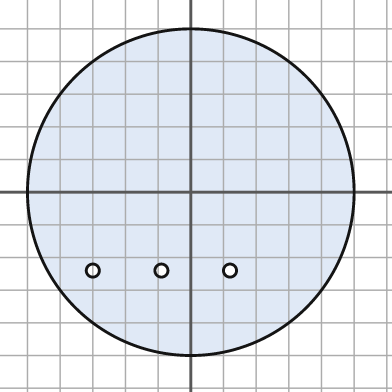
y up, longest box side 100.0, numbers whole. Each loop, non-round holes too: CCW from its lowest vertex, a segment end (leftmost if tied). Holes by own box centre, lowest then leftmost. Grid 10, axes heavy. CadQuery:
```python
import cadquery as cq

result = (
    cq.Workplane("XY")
    .moveTo(0.0, 0.0)
    .circle(50.0)
    .moveTo(-30.0, -24.0)
    .circle(2.0)
    .moveTo(-9.0, -24.0)
    .circle(2.0)
    .moveTo(12.0, -24.0)
    .circle(2.0)
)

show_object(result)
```